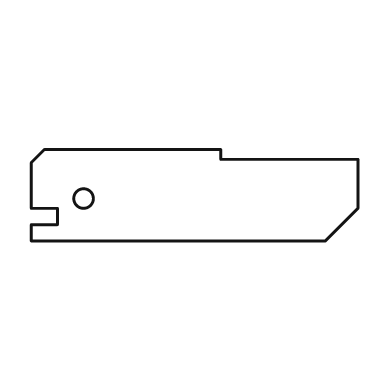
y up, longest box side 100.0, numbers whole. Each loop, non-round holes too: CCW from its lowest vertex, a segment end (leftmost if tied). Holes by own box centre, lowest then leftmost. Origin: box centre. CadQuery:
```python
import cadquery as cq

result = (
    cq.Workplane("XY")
    .moveTo(-50.0, -14.0)
    .lineTo(40.0, -14.0)
    .lineTo(50.0, -4.0)
    .lineTo(50.0, 11.0)
    .lineTo(8.0, 11.0)
    .lineTo(8.0, 14.0)
    .lineTo(-46.0, 14.0)
    .lineTo(-50.0, 10.0)
    .lineTo(-50.0, -4.0)
    .lineTo(-42.0, -4.0)
    .lineTo(-42.0, -9.0)
    .lineTo(-50.0, -9.0)
    .close()
    .moveTo(-34.0, -1.0)
    .circle(3.0)
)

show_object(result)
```